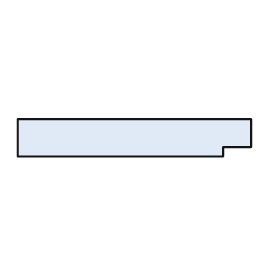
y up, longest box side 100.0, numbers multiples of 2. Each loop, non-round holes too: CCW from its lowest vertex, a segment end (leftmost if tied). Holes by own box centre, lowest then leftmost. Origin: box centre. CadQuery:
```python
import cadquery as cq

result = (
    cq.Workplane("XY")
    .moveTo(-50.0, -8.0)
    .lineTo(38.0, -8.0)
    .lineTo(38.0, -4.0)
    .lineTo(50.0, -4.0)
    .lineTo(50.0, 8.0)
    .lineTo(-50.0, 8.0)
    .close()
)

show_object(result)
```